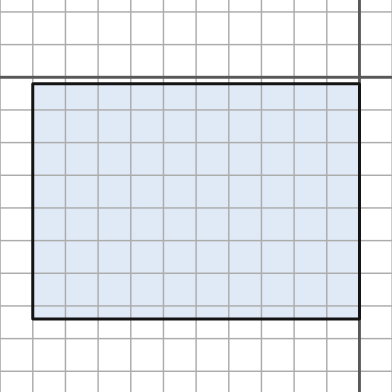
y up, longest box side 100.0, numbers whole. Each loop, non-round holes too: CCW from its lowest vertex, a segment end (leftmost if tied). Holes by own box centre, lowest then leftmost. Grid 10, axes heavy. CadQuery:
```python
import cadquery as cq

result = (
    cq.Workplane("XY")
    .moveTo(-100.0, -74.0)
    .lineTo(0.0, -74.0)
    .lineTo(0.0, -2.0)
    .lineTo(-100.0, -2.0)
    .close()
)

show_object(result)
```